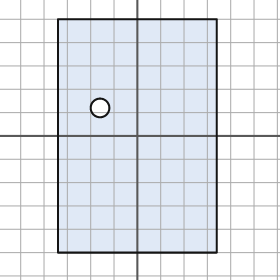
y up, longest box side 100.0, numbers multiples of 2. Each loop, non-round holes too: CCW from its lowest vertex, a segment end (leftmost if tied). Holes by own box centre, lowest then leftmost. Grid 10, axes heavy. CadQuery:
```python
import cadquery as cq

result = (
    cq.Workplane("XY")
    .moveTo(-34.0, -50.0)
    .lineTo(34.0, -50.0)
    .lineTo(34.0, 50.0)
    .lineTo(-34.0, 50.0)
    .close()
    .moveTo(-16.0, 12.0)
    .circle(4.0)
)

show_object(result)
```